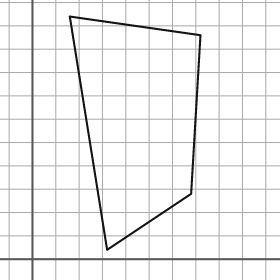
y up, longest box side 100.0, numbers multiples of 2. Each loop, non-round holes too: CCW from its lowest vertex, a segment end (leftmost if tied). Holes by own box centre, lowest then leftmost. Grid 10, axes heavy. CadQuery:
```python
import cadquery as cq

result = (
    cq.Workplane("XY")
    .moveTo(32.0, 4.0)
    .lineTo(68.0, 28.0)
    .lineTo(72.0, 96.0)
    .lineTo(16.0, 104.0)
    .close()
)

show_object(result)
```